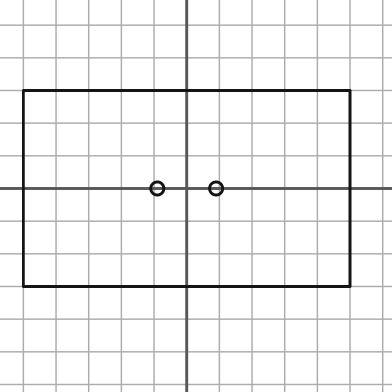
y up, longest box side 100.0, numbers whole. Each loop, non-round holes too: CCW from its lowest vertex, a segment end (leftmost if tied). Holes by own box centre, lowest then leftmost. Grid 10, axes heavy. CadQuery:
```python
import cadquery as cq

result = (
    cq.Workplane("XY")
    .moveTo(-50.0, -30.0)
    .lineTo(50.0, -30.0)
    .lineTo(50.0, 30.0)
    .lineTo(-50.0, 30.0)
    .close()
    .moveTo(-9.0, 0.0)
    .circle(2.0)
    .moveTo(9.0, 0.0)
    .circle(2.0)
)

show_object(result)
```